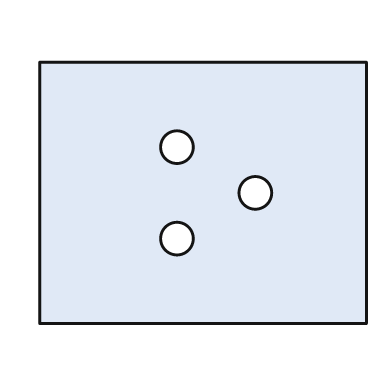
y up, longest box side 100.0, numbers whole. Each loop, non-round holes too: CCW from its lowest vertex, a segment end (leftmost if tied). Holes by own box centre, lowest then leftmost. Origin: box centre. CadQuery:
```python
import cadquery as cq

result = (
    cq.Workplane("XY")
    .moveTo(-50.0, -40.0)
    .lineTo(50.0, -40.0)
    .lineTo(50.0, 40.0)
    .lineTo(-50.0, 40.0)
    .close()
    .moveTo(-8.0, -14.0)
    .circle(5.0)
    .moveTo(16.0, 0.0)
    .circle(5.0)
    .moveTo(-8.0, 14.0)
    .circle(5.0)
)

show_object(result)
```